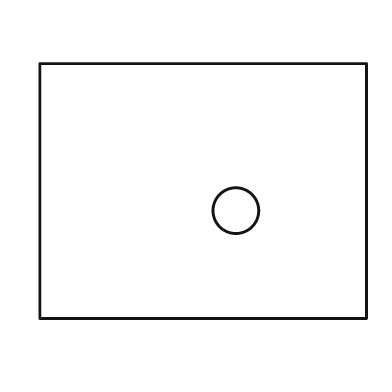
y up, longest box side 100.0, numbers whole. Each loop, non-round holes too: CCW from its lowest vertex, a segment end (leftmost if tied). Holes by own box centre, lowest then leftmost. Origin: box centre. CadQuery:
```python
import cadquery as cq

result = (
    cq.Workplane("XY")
    .moveTo(-50.0, -39.0)
    .lineTo(50.0, -39.0)
    .lineTo(50.0, 39.0)
    .lineTo(-50.0, 39.0)
    .close()
    .moveTo(10.0, -6.0)
    .circle(7.0)
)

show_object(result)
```